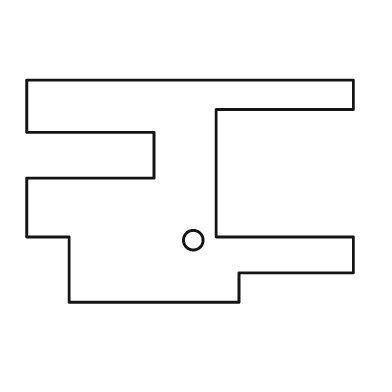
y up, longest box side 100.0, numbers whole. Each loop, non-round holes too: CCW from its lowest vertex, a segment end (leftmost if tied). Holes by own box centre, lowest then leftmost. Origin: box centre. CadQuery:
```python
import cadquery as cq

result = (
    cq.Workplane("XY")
    .moveTo(-37.0, -34.0)
    .lineTo(15.0, -34.0)
    .lineTo(15.0, -25.0)
    .lineTo(50.0, -25.0)
    .lineTo(50.0, -14.0)
    .lineTo(8.0, -14.0)
    .lineTo(8.0, 25.0)
    .lineTo(50.0, 25.0)
    .lineTo(50.0, 34.0)
    .lineTo(-50.0, 34.0)
    .lineTo(-50.0, 18.0)
    .lineTo(-11.0, 18.0)
    .lineTo(-11.0, 4.0)
    .lineTo(-50.0, 4.0)
    .lineTo(-50.0, -14.0)
    .lineTo(-37.0, -14.0)
    .close()
    .moveTo(1.0, -15.0)
    .circle(3.0)
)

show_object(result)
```